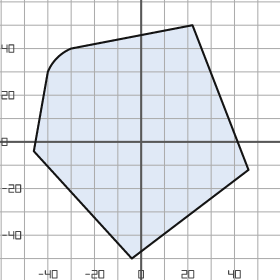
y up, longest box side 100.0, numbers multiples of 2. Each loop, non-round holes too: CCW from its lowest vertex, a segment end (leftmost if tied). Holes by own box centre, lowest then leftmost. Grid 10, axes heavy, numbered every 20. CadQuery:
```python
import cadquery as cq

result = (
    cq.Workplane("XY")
    .moveTo(-4.0, -50.0)
    .lineTo(46.0, -12.0)
    .lineTo(22.0, 50.0)
    .lineTo(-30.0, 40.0)
    .threePointArc((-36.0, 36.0), (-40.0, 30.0))
    .lineTo(-46.0, -4.0)
    .close()
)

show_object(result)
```